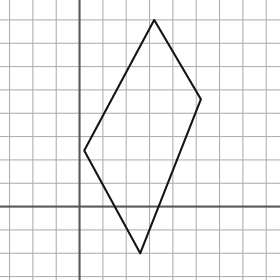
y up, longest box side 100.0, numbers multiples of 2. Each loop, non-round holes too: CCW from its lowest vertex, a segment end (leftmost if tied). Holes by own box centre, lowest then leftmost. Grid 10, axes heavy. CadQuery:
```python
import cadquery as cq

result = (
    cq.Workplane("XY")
    .moveTo(26.0, -20.0)
    .lineTo(52.0, 46.0)
    .lineTo(32.0, 80.0)
    .lineTo(2.0, 24.0)
    .close()
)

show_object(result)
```